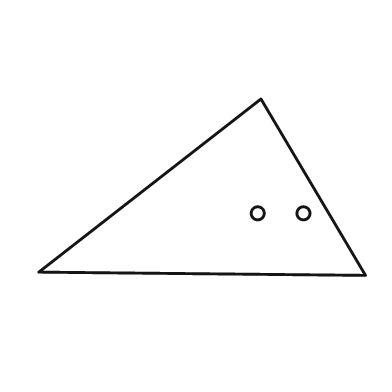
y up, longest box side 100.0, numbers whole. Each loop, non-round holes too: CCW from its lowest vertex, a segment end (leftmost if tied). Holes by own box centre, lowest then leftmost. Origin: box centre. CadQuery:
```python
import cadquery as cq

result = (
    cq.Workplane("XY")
    .moveTo(50.0, -27.0)
    .lineTo(18.0, 27.0)
    .lineTo(-50.0, -26.0)
    .close()
    .moveTo(17.0, -8.0)
    .circle(2.0)
    .moveTo(31.0, -8.0)
    .circle(2.0)
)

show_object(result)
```